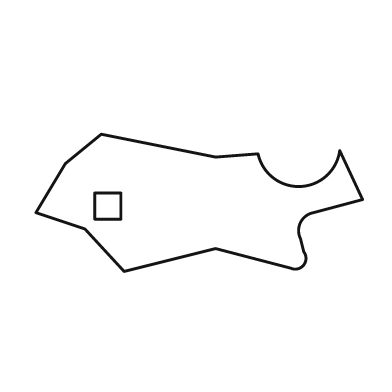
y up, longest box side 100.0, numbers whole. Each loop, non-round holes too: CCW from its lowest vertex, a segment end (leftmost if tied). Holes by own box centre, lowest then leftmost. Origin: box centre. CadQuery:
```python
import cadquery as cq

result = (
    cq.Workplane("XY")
    .moveTo(-23.0, -21.0)
    .lineTo(5.0, -14.0)
    .lineTo(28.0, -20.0)
    .threePointArc((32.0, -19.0), (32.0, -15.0))
    .lineTo(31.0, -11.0)
    .threePointArc((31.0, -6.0), (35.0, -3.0))
    .lineTo(50.0, 1.0)
    .lineTo(43.0, 16.0)
    .threePointArc((31.0, 5.0), (18.0, 15.0))
    .lineTo(5.0, 14.0)
    .lineTo(-30.0, 21.0)
    .lineTo(-41.0, 12.0)
    .lineTo(-50.0, -3.0)
    .lineTo(-35.0, -8.0)
    .close()
    .moveTo(-32.0, -5.0)
    .lineTo(-24.0, -5.0)
    .lineTo(-24.0, 3.0)
    .lineTo(-32.0, 3.0)
    .close()
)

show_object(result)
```